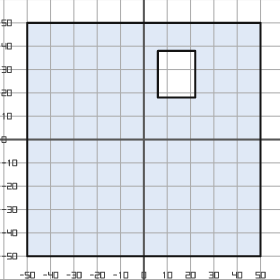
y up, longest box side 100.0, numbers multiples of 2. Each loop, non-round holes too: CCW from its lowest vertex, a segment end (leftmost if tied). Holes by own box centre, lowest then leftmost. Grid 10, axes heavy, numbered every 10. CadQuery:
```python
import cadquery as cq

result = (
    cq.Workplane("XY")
    .moveTo(-50.0, -50.0)
    .lineTo(50.0, -50.0)
    .lineTo(50.0, 50.0)
    .lineTo(-50.0, 50.0)
    .close()
    .moveTo(6.0, 18.0)
    .lineTo(22.0, 18.0)
    .lineTo(22.0, 38.0)
    .lineTo(6.0, 38.0)
    .close()
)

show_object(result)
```